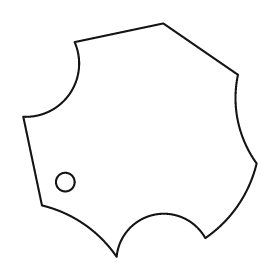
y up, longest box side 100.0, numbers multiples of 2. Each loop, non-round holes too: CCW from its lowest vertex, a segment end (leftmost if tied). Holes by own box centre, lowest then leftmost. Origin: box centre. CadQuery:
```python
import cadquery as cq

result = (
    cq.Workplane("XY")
    .moveTo(-10.0, -50.0)
    .threePointArc((6.0, -32.0), (28.0, -42.0))
    .threePointArc((42.0, -28.0), (50.0, -10.0))
    .threePointArc((42.0, 8.0), (42.0, 28.0))
    .lineTo(10.0, 50.0)
    .lineTo(-28.0, 42.0)
    .threePointArc((-30.0, 20.0), (-50.0, 10.0))
    .lineTo(-42.0, -28.0)
    .threePointArc((-24.0, -36.0), (-10.0, -50.0))
    .close()
    .moveTo(-32.0, -18.0)
    .circle(4.0)
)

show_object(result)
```